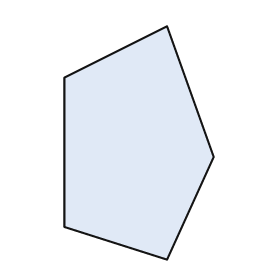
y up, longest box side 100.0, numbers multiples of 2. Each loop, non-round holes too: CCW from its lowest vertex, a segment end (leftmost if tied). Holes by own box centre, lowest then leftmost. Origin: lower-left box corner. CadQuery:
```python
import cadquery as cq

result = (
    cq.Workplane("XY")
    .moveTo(44.0, 0.0)
    .lineTo(64.0, 44.0)
    .lineTo(44.0, 100.0)
    .lineTo(0.0, 78.0)
    .lineTo(0.0, 14.0)
    .close()
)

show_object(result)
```